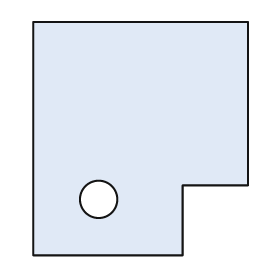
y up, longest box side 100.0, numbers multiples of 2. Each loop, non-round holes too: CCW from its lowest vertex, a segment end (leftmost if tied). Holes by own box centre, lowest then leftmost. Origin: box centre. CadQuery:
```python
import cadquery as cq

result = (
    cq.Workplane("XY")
    .moveTo(-46.0, -50.0)
    .lineTo(18.0, -50.0)
    .lineTo(18.0, -20.0)
    .lineTo(46.0, -20.0)
    .lineTo(46.0, 50.0)
    .lineTo(-46.0, 50.0)
    .close()
    .moveTo(-18.0, -26.0)
    .circle(8.0)
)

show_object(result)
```